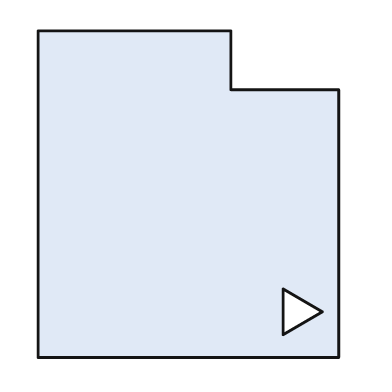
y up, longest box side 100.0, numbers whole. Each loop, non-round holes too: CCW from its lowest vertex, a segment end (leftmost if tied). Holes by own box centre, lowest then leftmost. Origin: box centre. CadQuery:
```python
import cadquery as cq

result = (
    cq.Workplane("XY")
    .moveTo(-46.0, -50.0)
    .lineTo(46.0, -50.0)
    .lineTo(46.0, 32.0)
    .lineTo(13.0, 32.0)
    .lineTo(13.0, 50.0)
    .lineTo(-46.0, 50.0)
    .close()
    .moveTo(29.0, -43.0)
    .lineTo(41.0, -36.0)
    .lineTo(29.0, -29.0)
    .close()
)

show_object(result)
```